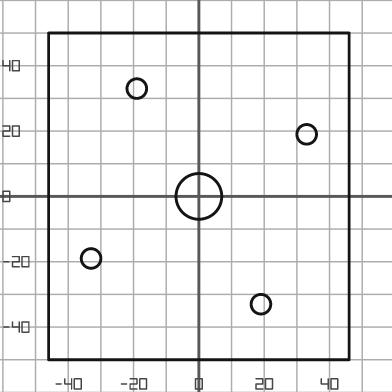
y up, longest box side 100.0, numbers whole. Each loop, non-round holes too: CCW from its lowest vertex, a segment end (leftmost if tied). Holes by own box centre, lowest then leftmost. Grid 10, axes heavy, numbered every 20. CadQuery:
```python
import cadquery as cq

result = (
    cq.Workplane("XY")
    .moveTo(-46.0, -50.0)
    .lineTo(46.0, -50.0)
    .lineTo(46.0, 50.0)
    .lineTo(-46.0, 50.0)
    .close()
    .moveTo(19.0, -33.0)
    .circle(3.0)
    .moveTo(-33.0, -19.0)
    .circle(3.0)
    .moveTo(0.0, 0.0)
    .circle(7.0)
    .moveTo(33.0, 19.0)
    .circle(3.0)
    .moveTo(-19.0, 33.0)
    .circle(3.0)
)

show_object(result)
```